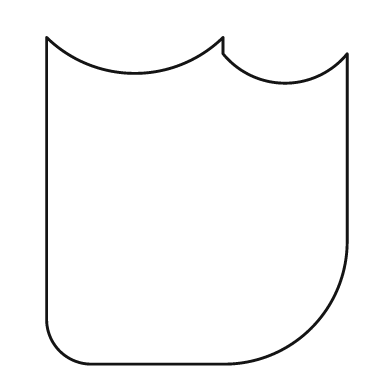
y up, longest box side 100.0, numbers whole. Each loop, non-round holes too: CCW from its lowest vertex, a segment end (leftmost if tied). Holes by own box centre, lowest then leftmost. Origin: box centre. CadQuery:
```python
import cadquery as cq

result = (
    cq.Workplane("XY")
    .moveTo(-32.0, -50.0)
    .lineTo(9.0, -50.0)
    .threePointArc((35.0, -39.0), (46.0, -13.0))
    .lineTo(46.0, 45.0)
    .threePointArc((27.0, 36.0), (8.0, 45.0))
    .lineTo(8.0, 50.0)
    .threePointArc((-19.0, 39.0), (-46.0, 50.0))
    .lineTo(-46.0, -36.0)
    .threePointArc((-42.0, -46.0), (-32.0, -50.0))
    .close()
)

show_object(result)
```